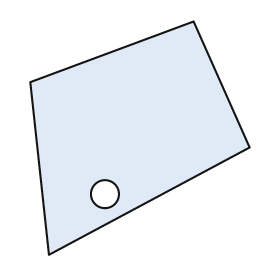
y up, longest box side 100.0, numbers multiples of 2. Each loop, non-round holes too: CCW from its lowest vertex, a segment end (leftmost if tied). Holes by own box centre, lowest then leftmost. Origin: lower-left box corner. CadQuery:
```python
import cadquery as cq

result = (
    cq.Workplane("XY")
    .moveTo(8.0, 0.0)
    .lineTo(94.0, 46.0)
    .lineTo(70.0, 100.0)
    .lineTo(0.0, 74.0)
    .close()
    .moveTo(32.0, 26.0)
    .circle(6.0)
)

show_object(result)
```